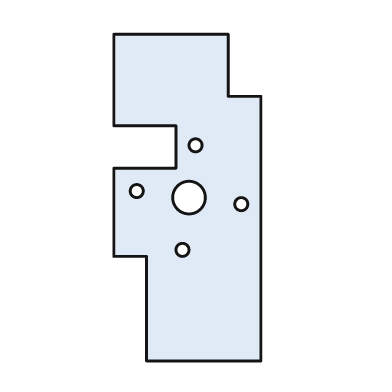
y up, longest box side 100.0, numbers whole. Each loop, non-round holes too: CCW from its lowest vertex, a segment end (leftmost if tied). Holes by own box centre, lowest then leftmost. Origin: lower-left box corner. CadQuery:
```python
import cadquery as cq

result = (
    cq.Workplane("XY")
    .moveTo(10.0, 0.0)
    .lineTo(45.0, 0.0)
    .lineTo(45.0, 81.0)
    .lineTo(35.0, 81.0)
    .lineTo(35.0, 100.0)
    .lineTo(0.0, 100.0)
    .lineTo(0.0, 72.0)
    .lineTo(19.0, 72.0)
    .lineTo(19.0, 59.0)
    .lineTo(0.0, 59.0)
    .lineTo(0.0, 32.0)
    .lineTo(10.0, 32.0)
    .close()
    .moveTo(21.0, 34.0)
    .circle(2.0)
    .moveTo(39.0, 48.0)
    .circle(2.0)
    .moveTo(23.0, 50.0)
    .circle(5.0)
    .moveTo(7.0, 52.0)
    .circle(2.0)
    .moveTo(25.0, 66.0)
    .circle(2.0)
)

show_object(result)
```